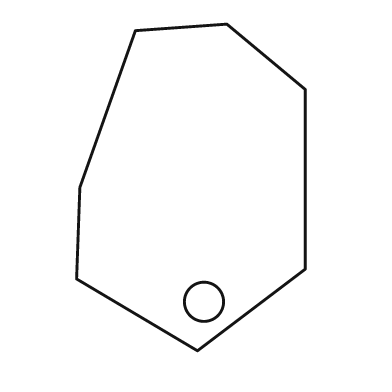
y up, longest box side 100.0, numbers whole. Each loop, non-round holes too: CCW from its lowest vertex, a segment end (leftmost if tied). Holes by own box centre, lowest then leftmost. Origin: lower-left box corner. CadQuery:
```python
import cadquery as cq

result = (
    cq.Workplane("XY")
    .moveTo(37.0, 0.0)
    .lineTo(70.0, 25.0)
    .lineTo(70.0, 80.0)
    .lineTo(46.0, 100.0)
    .lineTo(18.0, 98.0)
    .lineTo(1.0, 50.0)
    .lineTo(0.0, 22.0)
    .close()
    .moveTo(39.0, 15.0)
    .circle(6.0)
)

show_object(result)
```